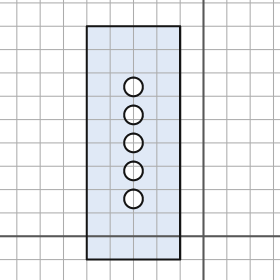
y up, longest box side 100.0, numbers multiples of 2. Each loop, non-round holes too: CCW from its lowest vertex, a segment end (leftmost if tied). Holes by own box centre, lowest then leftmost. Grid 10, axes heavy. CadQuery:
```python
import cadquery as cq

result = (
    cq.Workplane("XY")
    .moveTo(-50.0, -10.0)
    .lineTo(-10.0, -10.0)
    .lineTo(-10.0, 90.0)
    .lineTo(-50.0, 90.0)
    .close()
    .moveTo(-30.0, 16.0)
    .circle(4.0)
    .moveTo(-30.0, 28.0)
    .circle(4.0)
    .moveTo(-30.0, 40.0)
    .circle(4.0)
    .moveTo(-30.0, 52.0)
    .circle(4.0)
    .moveTo(-30.0, 64.0)
    .circle(4.0)
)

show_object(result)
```